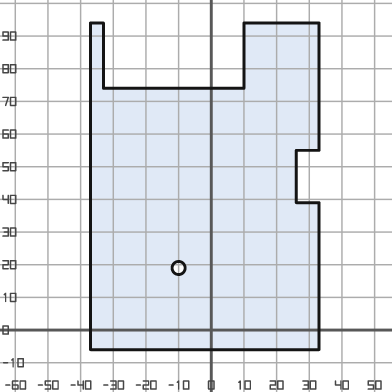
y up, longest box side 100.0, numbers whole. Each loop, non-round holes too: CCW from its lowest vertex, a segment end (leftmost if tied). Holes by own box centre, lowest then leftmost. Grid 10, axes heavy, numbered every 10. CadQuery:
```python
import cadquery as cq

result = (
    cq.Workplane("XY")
    .moveTo(-37.0, -6.0)
    .lineTo(33.0, -6.0)
    .lineTo(33.0, 39.0)
    .lineTo(26.0, 39.0)
    .lineTo(26.0, 55.0)
    .lineTo(33.0, 55.0)
    .lineTo(33.0, 94.0)
    .lineTo(10.0, 94.0)
    .lineTo(10.0, 74.0)
    .lineTo(-33.0, 74.0)
    .lineTo(-33.0, 94.0)
    .lineTo(-37.0, 94.0)
    .close()
    .moveTo(-10.0, 19.0)
    .circle(2.0)
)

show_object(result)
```